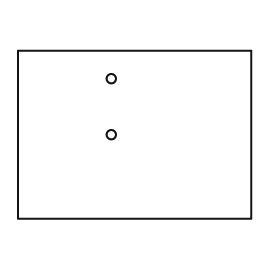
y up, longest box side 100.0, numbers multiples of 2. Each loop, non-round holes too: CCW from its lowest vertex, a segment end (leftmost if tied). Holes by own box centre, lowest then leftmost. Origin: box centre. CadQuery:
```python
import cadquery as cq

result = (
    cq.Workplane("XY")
    .moveTo(-50.0, -36.0)
    .lineTo(50.0, -36.0)
    .lineTo(50.0, 36.0)
    .lineTo(-50.0, 36.0)
    .close()
    .moveTo(-10.0, 0.0)
    .circle(2.0)
    .moveTo(-10.0, 24.0)
    .circle(2.0)
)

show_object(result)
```